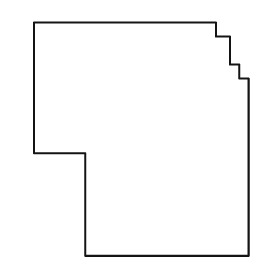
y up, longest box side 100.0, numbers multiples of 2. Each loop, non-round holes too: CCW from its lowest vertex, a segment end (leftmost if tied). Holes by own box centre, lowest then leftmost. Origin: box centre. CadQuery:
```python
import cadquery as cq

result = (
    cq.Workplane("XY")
    .moveTo(-24.0, -50.0)
    .lineTo(46.0, -50.0)
    .lineTo(46.0, 26.0)
    .lineTo(42.0, 26.0)
    .lineTo(42.0, 32.0)
    .lineTo(38.0, 32.0)
    .lineTo(38.0, 44.0)
    .lineTo(32.0, 44.0)
    .lineTo(32.0, 50.0)
    .lineTo(-46.0, 50.0)
    .lineTo(-46.0, -6.0)
    .lineTo(-24.0, -6.0)
    .close()
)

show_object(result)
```